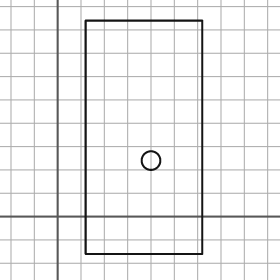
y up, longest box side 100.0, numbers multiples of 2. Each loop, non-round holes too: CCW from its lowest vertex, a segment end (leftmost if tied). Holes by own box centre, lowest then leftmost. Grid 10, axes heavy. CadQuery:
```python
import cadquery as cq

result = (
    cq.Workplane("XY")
    .moveTo(12.0, -16.0)
    .lineTo(62.0, -16.0)
    .lineTo(62.0, 84.0)
    .lineTo(12.0, 84.0)
    .close()
    .moveTo(40.0, 24.0)
    .circle(4.0)
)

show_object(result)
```